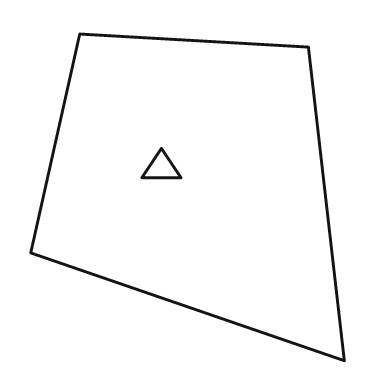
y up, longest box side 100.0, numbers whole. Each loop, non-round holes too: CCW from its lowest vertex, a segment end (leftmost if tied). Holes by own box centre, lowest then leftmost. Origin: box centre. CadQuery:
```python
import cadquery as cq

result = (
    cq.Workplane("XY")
    .moveTo(48.0, -50.0)
    .lineTo(37.0, 46.0)
    .lineTo(-33.0, 50.0)
    .lineTo(-48.0, -17.0)
    .close()
    .moveTo(-14.0, 6.0)
    .lineTo(-2.0, 6.0)
    .lineTo(-8.0, 15.0)
    .close()
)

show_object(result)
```